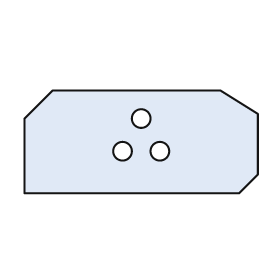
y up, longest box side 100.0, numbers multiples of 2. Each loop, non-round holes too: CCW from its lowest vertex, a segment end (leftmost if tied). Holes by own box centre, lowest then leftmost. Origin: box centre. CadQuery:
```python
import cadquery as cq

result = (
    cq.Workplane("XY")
    .moveTo(-50.0, -22.0)
    .lineTo(42.0, -22.0)
    .lineTo(50.0, -14.0)
    .lineTo(50.0, 12.0)
    .lineTo(34.0, 22.0)
    .lineTo(-38.0, 22.0)
    .lineTo(-50.0, 10.0)
    .close()
    .moveTo(-8.0, -4.0)
    .circle(4.0)
    .moveTo(8.0, -4.0)
    .circle(4.0)
    .moveTo(0.0, 10.0)
    .circle(4.0)
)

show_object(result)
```